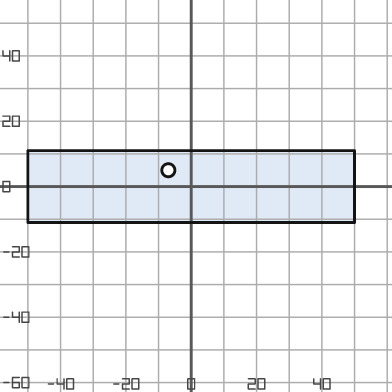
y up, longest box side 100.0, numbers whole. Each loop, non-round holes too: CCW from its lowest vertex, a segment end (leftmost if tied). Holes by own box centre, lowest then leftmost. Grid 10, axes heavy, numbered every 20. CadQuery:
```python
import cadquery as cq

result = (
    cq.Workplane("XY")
    .moveTo(-50.0, -11.0)
    .lineTo(50.0, -11.0)
    .lineTo(50.0, 11.0)
    .lineTo(-50.0, 11.0)
    .close()
    .moveTo(-7.0, 5.0)
    .circle(2.0)
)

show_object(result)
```